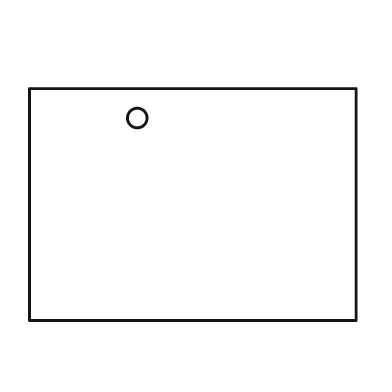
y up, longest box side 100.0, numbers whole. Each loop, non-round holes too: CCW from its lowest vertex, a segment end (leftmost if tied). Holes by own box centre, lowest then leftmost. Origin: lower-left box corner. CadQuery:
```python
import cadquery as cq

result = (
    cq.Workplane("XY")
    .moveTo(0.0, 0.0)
    .lineTo(100.0, 0.0)
    .lineTo(100.0, 71.0)
    .lineTo(0.0, 71.0)
    .close()
    .moveTo(33.0, 62.0)
    .circle(3.0)
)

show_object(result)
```